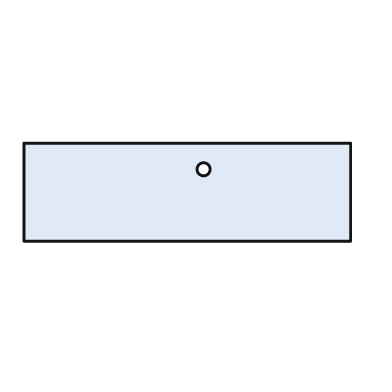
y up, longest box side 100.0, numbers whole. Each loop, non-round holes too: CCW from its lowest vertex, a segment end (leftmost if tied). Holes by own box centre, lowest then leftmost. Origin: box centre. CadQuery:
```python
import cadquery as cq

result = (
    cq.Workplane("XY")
    .moveTo(-50.0, -15.0)
    .lineTo(50.0, -15.0)
    .lineTo(50.0, 15.0)
    .lineTo(-50.0, 15.0)
    .close()
    .moveTo(5.0, 7.0)
    .circle(2.0)
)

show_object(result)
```